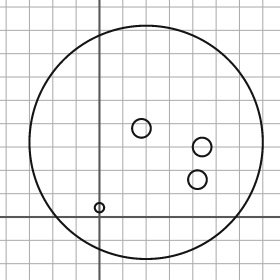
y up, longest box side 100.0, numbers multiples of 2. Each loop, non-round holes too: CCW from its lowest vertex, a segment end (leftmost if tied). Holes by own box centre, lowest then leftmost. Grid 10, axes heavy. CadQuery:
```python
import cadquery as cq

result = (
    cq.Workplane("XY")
    .moveTo(20.0, 32.0)
    .circle(50.0)
    .moveTo(0.0, 4.0)
    .circle(2.0)
    .moveTo(42.0, 16.0)
    .circle(4.0)
    .moveTo(44.0, 30.0)
    .circle(4.0)
    .moveTo(18.0, 38.0)
    .circle(4.0)
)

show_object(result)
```